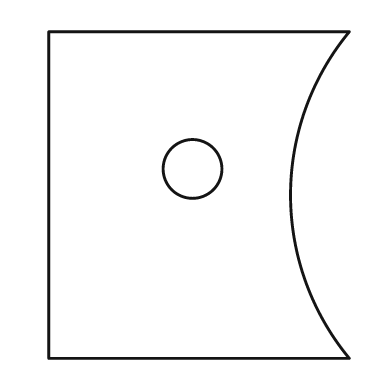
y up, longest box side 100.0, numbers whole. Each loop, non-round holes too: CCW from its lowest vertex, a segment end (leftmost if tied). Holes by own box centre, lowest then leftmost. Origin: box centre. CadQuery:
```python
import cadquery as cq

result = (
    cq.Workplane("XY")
    .moveTo(-46.0, -50.0)
    .lineTo(46.0, -50.0)
    .threePointArc((28.0, 0.0), (46.0, 50.0))
    .lineTo(-46.0, 50.0)
    .close()
    .moveTo(-2.0, 8.0)
    .circle(9.0)
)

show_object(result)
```